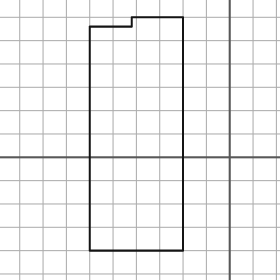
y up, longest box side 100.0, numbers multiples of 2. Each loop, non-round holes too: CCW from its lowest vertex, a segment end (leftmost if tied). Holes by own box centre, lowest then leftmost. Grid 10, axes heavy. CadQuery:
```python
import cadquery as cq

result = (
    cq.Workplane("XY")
    .moveTo(-60.0, -40.0)
    .lineTo(-20.0, -40.0)
    .lineTo(-20.0, 60.0)
    .lineTo(-42.0, 60.0)
    .lineTo(-42.0, 56.0)
    .lineTo(-60.0, 56.0)
    .close()
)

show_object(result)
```